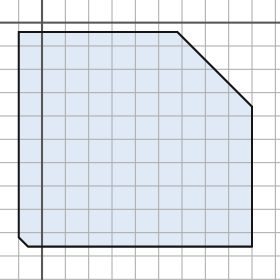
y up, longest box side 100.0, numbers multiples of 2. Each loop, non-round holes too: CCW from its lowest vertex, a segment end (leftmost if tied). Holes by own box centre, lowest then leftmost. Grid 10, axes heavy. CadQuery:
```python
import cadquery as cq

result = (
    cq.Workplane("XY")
    .moveTo(-6.0, -96.0)
    .lineTo(90.0, -96.0)
    .lineTo(90.0, -36.0)
    .lineTo(58.0, -4.0)
    .lineTo(-10.0, -4.0)
    .lineTo(-10.0, -92.0)
    .close()
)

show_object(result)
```